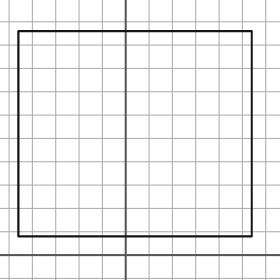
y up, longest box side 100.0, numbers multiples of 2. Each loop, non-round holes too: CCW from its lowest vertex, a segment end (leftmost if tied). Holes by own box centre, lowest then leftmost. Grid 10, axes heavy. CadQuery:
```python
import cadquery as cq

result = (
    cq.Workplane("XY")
    .moveTo(-46.0, 8.0)
    .lineTo(54.0, 8.0)
    .lineTo(54.0, 96.0)
    .lineTo(-46.0, 96.0)
    .close()
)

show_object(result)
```